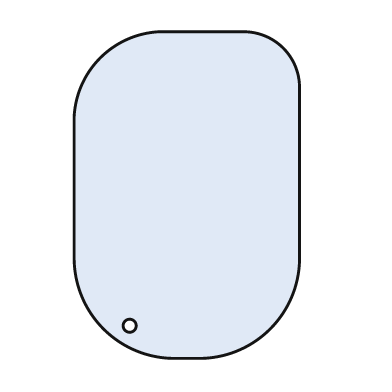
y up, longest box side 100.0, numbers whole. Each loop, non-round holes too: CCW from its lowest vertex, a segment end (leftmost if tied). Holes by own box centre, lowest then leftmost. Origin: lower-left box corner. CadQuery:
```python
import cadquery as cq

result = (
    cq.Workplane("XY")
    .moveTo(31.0, 0.0)
    .lineTo(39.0, 0.0)
    .threePointArc((60.0, 9.0), (69.0, 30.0))
    .lineTo(69.0, 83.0)
    .threePointArc((64.0, 95.0), (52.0, 100.0))
    .lineTo(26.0, 100.0)
    .threePointArc((8.0, 92.0), (0.0, 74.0))
    .lineTo(0.0, 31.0)
    .threePointArc((9.0, 9.0), (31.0, 0.0))
    .close()
    .moveTo(17.0, 10.0)
    .circle(2.0)
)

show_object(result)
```